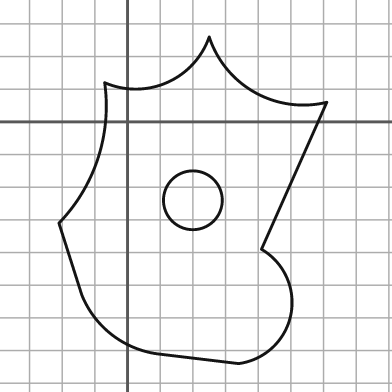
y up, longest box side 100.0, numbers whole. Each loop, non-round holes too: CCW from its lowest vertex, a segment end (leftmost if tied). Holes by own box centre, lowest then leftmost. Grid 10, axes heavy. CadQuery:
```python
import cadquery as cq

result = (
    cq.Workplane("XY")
    .moveTo(34.0, -74.0)
    .threePointArc((50.0, -59.0), (41.0, -39.0))
    .lineTo(61.0, 6.0)
    .threePointArc((39.0, 9.0), (25.0, 26.0))
    .threePointArc((12.0, 12.0), (-7.0, 12.0))
    .threePointArc((-9.0, -11.0), (-21.0, -31.0))
    .lineTo(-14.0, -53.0)
    .threePointArc((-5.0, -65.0), (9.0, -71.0))
    .close()
    .moveTo(20.0, -24.0)
    .circle(9.0)
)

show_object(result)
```